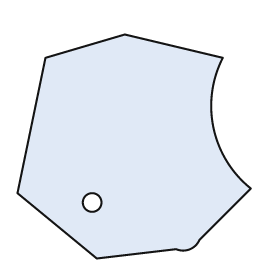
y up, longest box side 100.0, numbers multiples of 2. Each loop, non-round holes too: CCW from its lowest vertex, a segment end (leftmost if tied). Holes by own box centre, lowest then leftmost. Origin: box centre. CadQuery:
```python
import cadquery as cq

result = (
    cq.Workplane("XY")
    .moveTo(-16.0, -48.0)
    .lineTo(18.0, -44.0)
    .threePointArc((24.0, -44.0), (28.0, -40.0))
    .lineTo(50.0, -18.0)
    .threePointArc((34.0, 8.0), (38.0, 38.0))
    .lineTo(-4.0, 48.0)
    .lineTo(-38.0, 38.0)
    .lineTo(-50.0, -20.0)
    .close()
    .moveTo(-18.0, -24.0)
    .circle(4.0)
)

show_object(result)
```